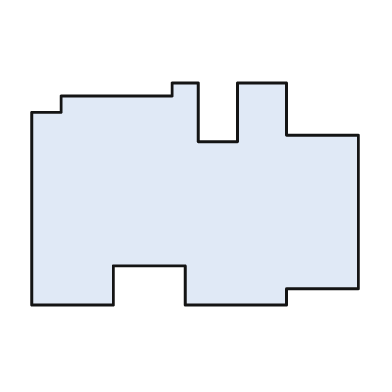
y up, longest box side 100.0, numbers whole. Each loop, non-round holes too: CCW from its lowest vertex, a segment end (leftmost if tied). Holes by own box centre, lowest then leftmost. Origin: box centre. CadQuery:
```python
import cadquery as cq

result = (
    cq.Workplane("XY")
    .moveTo(-50.0, -34.0)
    .lineTo(-25.0, -34.0)
    .lineTo(-25.0, -22.0)
    .lineTo(-3.0, -22.0)
    .lineTo(-3.0, -34.0)
    .lineTo(28.0, -34.0)
    .lineTo(28.0, -29.0)
    .lineTo(50.0, -29.0)
    .lineTo(50.0, 18.0)
    .lineTo(28.0, 18.0)
    .lineTo(28.0, 34.0)
    .lineTo(13.0, 34.0)
    .lineTo(13.0, 16.0)
    .lineTo(1.0, 16.0)
    .lineTo(1.0, 34.0)
    .lineTo(-7.0, 34.0)
    .lineTo(-7.0, 30.0)
    .lineTo(-41.0, 30.0)
    .lineTo(-41.0, 25.0)
    .lineTo(-50.0, 25.0)
    .close()
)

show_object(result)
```